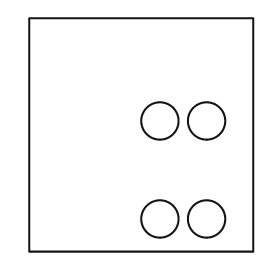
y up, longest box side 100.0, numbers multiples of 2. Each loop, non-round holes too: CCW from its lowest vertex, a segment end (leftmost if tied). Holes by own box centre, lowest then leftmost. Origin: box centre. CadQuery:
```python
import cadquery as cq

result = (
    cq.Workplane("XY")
    .moveTo(-48.0, -50.0)
    .lineTo(48.0, -50.0)
    .lineTo(48.0, 50.0)
    .lineTo(-48.0, 50.0)
    .close()
    .moveTo(8.0, -36.0)
    .circle(8.0)
    .moveTo(28.0, -36.0)
    .circle(8.0)
    .moveTo(8.0, 6.0)
    .circle(8.0)
    .moveTo(28.0, 6.0)
    .circle(8.0)
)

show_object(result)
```